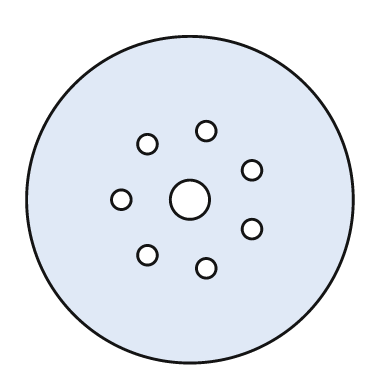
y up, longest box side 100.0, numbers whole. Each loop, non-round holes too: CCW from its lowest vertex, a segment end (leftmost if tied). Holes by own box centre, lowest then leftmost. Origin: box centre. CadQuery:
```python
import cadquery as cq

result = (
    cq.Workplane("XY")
    .moveTo(0.0, 0.0)
    .circle(50.0)
    .moveTo(5.0, -21.0)
    .circle(3.0)
    .moveTo(-13.0, -17.0)
    .circle(3.0)
    .moveTo(19.0, -9.0)
    .circle(3.0)
    .moveTo(-21.0, 0.0)
    .circle(3.0)
    .moveTo(0.0, 0.0)
    .circle(6.0)
    .moveTo(19.0, 9.0)
    .circle(3.0)
    .moveTo(-13.0, 17.0)
    .circle(3.0)
    .moveTo(5.0, 21.0)
    .circle(3.0)
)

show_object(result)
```